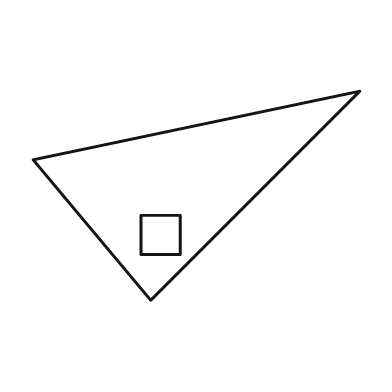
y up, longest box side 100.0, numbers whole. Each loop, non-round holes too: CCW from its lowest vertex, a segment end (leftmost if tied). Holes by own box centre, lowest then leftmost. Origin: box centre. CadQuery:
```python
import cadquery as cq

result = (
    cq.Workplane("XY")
    .moveTo(-14.0, -32.0)
    .lineTo(50.0, 32.0)
    .lineTo(-50.0, 11.0)
    .close()
    .moveTo(-17.0, -18.0)
    .lineTo(-5.0, -18.0)
    .lineTo(-5.0, -6.0)
    .lineTo(-17.0, -6.0)
    .close()
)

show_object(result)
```